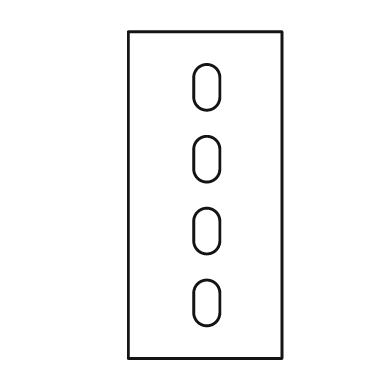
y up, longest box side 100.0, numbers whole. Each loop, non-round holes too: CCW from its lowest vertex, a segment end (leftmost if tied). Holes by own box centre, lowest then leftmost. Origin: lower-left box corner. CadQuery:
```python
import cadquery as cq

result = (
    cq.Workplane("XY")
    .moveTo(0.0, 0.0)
    .lineTo(47.0, 0.0)
    .lineTo(47.0, 100.0)
    .lineTo(0.0, 100.0)
    .close()
    .moveTo(20.0, 14.0)
    .threePointArc((24.0, 10.0), (28.0, 14.0))
    .lineTo(28.0, 20.0)
    .threePointArc((24.0, 24.0), (20.0, 20.0))
    .close()
    .moveTo(20.0, 36.0)
    .threePointArc((24.0, 32.0), (28.0, 36.0))
    .lineTo(28.0, 42.0)
    .threePointArc((24.0, 46.0), (20.0, 42.0))
    .close()
    .moveTo(20.0, 58.0)
    .threePointArc((24.0, 54.0), (28.0, 58.0))
    .lineTo(28.0, 64.0)
    .threePointArc((24.0, 68.0), (20.0, 64.0))
    .close()
    .moveTo(20.0, 80.0)
    .threePointArc((24.0, 76.0), (28.0, 80.0))
    .lineTo(28.0, 86.0)
    .threePointArc((24.0, 90.0), (20.0, 86.0))
    .close()
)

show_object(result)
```